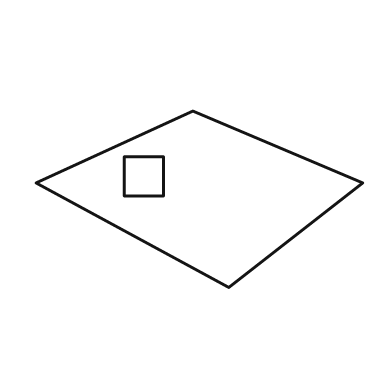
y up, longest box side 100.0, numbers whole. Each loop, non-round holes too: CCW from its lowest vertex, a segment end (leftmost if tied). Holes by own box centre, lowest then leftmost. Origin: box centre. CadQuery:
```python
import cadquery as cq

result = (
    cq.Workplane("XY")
    .moveTo(9.0, -27.0)
    .lineTo(50.0, 5.0)
    .lineTo(-2.0, 27.0)
    .lineTo(-50.0, 5.0)
    .close()
    .moveTo(-23.0, 1.0)
    .lineTo(-11.0, 1.0)
    .lineTo(-11.0, 13.0)
    .lineTo(-23.0, 13.0)
    .close()
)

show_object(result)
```